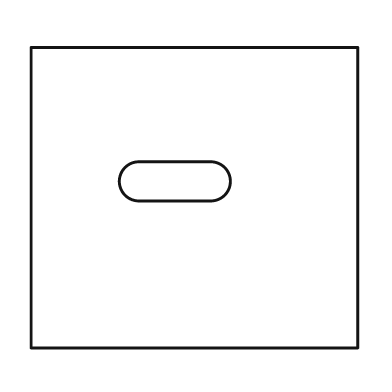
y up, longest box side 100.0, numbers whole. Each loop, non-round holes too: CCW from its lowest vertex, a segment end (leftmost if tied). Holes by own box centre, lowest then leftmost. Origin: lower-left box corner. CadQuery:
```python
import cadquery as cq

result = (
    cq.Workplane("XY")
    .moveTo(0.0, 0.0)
    .lineTo(100.0, 0.0)
    .lineTo(100.0, 92.0)
    .lineTo(0.0, 92.0)
    .close()
    .moveTo(33.0, 45.0)
    .lineTo(55.0, 45.0)
    .threePointArc((61.0, 51.0), (55.0, 57.0))
    .lineTo(33.0, 57.0)
    .threePointArc((27.0, 51.0), (33.0, 45.0))
    .close()
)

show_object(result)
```